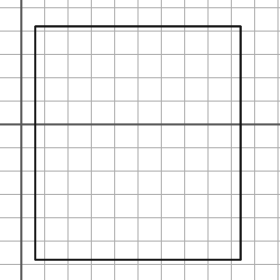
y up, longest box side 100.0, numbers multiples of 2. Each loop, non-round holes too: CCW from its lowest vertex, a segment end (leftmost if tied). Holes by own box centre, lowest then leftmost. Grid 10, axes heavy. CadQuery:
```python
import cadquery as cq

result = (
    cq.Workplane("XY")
    .moveTo(6.0, -58.0)
    .lineTo(94.0, -58.0)
    .lineTo(94.0, 42.0)
    .lineTo(6.0, 42.0)
    .close()
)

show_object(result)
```